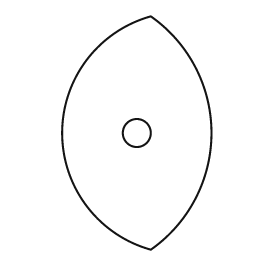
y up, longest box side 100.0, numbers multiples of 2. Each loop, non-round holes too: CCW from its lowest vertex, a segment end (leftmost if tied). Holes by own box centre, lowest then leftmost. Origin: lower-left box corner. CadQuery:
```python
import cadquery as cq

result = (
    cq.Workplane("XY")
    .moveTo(38.0, 0.0)
    .threePointArc((64.0, 50.0), (38.0, 100.0))
    .threePointArc((0.0, 50.0), (38.0, 0.0))
    .close()
    .moveTo(32.0, 50.0)
    .circle(6.0)
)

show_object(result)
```